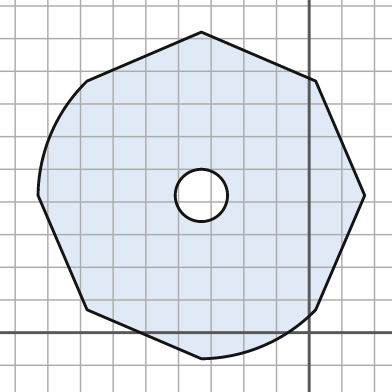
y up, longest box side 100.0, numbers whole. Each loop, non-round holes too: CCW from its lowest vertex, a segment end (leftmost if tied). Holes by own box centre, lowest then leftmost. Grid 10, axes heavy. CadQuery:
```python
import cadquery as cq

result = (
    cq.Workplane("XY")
    .moveTo(-33.0, -8.0)
    .threePointArc((-14.0, -4.0), (2.0, 7.0))
    .lineTo(17.0, 42.0)
    .lineTo(2.0, 77.0)
    .lineTo(-33.0, 92.0)
    .lineTo(-68.0, 77.0)
    .threePointArc((-79.0, 61.0), (-83.0, 42.0))
    .lineTo(-68.0, 7.0)
    .close()
    .moveTo(-33.0, 42.0)
    .circle(8.0)
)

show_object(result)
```